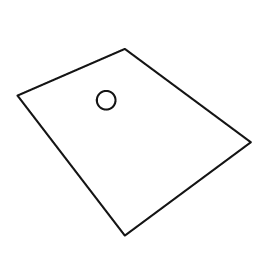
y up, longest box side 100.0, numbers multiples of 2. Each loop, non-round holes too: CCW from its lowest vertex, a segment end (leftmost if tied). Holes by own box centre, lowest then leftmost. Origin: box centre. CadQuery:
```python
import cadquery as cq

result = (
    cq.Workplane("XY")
    .moveTo(-4.0, -40.0)
    .lineTo(50.0, 0.0)
    .lineTo(-4.0, 40.0)
    .lineTo(-50.0, 20.0)
    .close()
    .moveTo(-12.0, 18.0)
    .circle(4.0)
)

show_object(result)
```